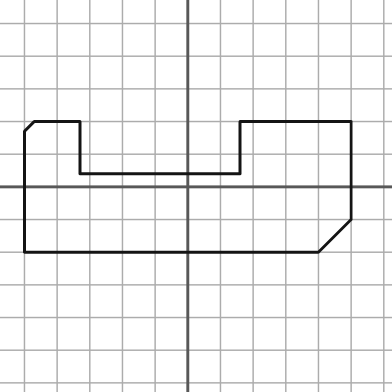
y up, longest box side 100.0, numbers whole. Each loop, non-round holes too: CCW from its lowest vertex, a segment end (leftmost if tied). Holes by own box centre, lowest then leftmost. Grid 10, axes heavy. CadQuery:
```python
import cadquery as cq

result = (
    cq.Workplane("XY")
    .moveTo(-50.0, -20.0)
    .lineTo(40.0, -20.0)
    .lineTo(50.0, -10.0)
    .lineTo(50.0, 20.0)
    .lineTo(16.0, 20.0)
    .lineTo(16.0, 4.0)
    .lineTo(-33.0, 4.0)
    .lineTo(-33.0, 20.0)
    .lineTo(-47.0, 20.0)
    .lineTo(-50.0, 17.0)
    .close()
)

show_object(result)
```